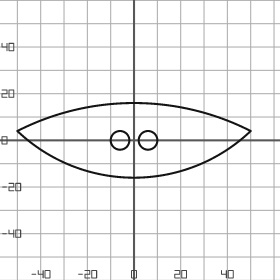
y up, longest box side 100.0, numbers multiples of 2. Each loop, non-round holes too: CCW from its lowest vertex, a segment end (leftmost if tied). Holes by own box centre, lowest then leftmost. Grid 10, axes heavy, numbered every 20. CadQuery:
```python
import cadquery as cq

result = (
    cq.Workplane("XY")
    .moveTo(-50.0, 4.0)
    .threePointArc((0.0, -16.0), (50.0, 4.0))
    .threePointArc((0.0, 16.0), (-50.0, 4.0))
    .close()
    .moveTo(-6.0, 0.0)
    .circle(4.0)
    .moveTo(6.0, 0.0)
    .circle(4.0)
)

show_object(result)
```